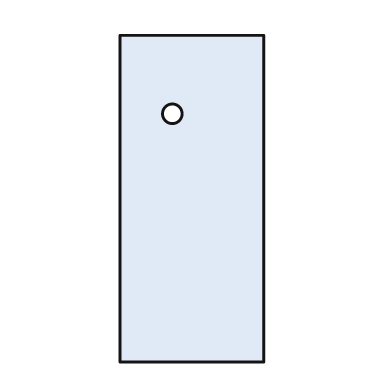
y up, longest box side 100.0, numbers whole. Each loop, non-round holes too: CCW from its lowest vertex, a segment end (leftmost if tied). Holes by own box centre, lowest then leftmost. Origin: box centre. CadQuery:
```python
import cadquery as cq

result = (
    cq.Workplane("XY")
    .moveTo(-22.0, -50.0)
    .lineTo(22.0, -50.0)
    .lineTo(22.0, 50.0)
    .lineTo(-22.0, 50.0)
    .close()
    .moveTo(-6.0, 26.0)
    .circle(3.0)
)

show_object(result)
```